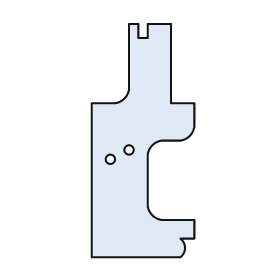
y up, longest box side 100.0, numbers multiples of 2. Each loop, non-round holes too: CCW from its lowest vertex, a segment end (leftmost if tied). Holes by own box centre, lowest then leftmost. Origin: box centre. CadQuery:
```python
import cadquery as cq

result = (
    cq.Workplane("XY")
    .moveTo(-22.0, -50.0)
    .lineTo(16.0, -50.0)
    .threePointArc((18.0, -46.0), (16.0, -42.0))
    .lineTo(22.0, -42.0)
    .lineTo(22.0, -34.0)
    .lineTo(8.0, -34.0)
    .threePointArc((4.0, -32.0), (2.0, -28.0))
    .lineTo(2.0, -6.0)
    .threePointArc((4.0, -2.0), (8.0, 0.0))
    .lineTo(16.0, 0.0)
    .threePointArc((20.0, 2.0), (22.0, 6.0))
    .lineTo(22.0, 16.0)
    .lineTo(12.0, 16.0)
    .lineTo(12.0, 50.0)
    .lineTo(2.0, 50.0)
    .lineTo(2.0, 44.0)
    .lineTo(-2.0, 44.0)
    .lineTo(-2.0, 50.0)
    .lineTo(-6.0, 50.0)
    .lineTo(-6.0, 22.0)
    .threePointArc((-8.0, 18.0), (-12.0, 16.0))
    .lineTo(-22.0, 16.0)
    .close()
    .moveTo(-14.0, -8.0)
    .circle(2.0)
    .moveTo(-6.0, -4.0)
    .circle(2.0)
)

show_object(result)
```